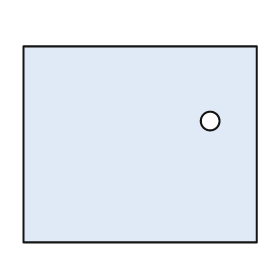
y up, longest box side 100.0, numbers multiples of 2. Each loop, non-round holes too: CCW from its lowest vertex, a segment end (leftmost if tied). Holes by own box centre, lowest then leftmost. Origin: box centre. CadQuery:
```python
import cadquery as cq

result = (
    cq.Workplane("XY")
    .moveTo(-50.0, -42.0)
    .lineTo(50.0, -42.0)
    .lineTo(50.0, 42.0)
    .lineTo(-50.0, 42.0)
    .close()
    .moveTo(30.0, 10.0)
    .circle(4.0)
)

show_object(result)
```